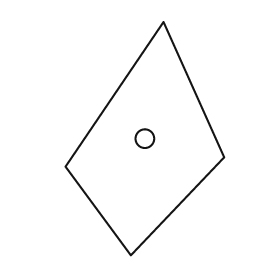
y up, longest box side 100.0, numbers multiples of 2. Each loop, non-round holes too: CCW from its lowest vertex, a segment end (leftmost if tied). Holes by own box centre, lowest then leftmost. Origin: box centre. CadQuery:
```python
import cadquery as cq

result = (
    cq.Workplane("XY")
    .moveTo(-6.0, -50.0)
    .lineTo(34.0, -8.0)
    .lineTo(8.0, 50.0)
    .lineTo(-34.0, -12.0)
    .close()
    .moveTo(0.0, 0.0)
    .circle(4.0)
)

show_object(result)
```